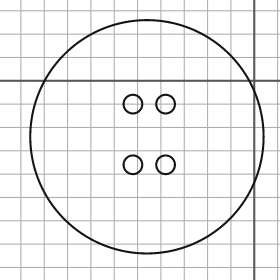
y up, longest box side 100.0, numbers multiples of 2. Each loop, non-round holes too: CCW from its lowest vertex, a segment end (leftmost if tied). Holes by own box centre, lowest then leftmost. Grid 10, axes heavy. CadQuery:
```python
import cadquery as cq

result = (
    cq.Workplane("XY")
    .moveTo(-46.0, -24.0)
    .circle(50.0)
    .moveTo(-52.0, -36.0)
    .circle(4.0)
    .moveTo(-38.0, -36.0)
    .circle(4.0)
    .moveTo(-52.0, -10.0)
    .circle(4.0)
    .moveTo(-38.0, -10.0)
    .circle(4.0)
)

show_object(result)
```